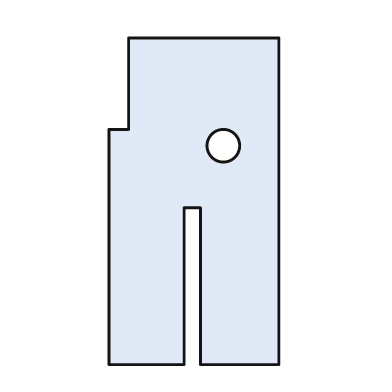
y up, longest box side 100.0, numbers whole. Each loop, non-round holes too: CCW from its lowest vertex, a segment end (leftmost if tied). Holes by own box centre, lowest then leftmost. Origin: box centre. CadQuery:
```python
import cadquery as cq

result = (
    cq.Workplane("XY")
    .moveTo(-26.0, -50.0)
    .lineTo(-3.0, -50.0)
    .lineTo(-3.0, -2.0)
    .lineTo(2.0, -2.0)
    .lineTo(2.0, -50.0)
    .lineTo(26.0, -50.0)
    .lineTo(26.0, 50.0)
    .lineTo(-20.0, 50.0)
    .lineTo(-20.0, 22.0)
    .lineTo(-26.0, 22.0)
    .close()
    .moveTo(9.0, 17.0)
    .circle(5.0)
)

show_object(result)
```